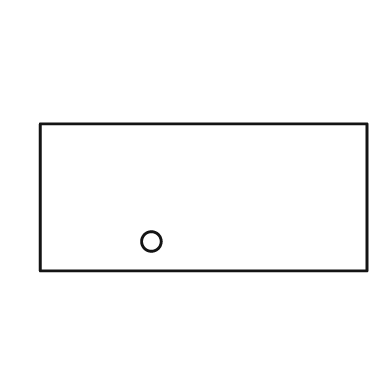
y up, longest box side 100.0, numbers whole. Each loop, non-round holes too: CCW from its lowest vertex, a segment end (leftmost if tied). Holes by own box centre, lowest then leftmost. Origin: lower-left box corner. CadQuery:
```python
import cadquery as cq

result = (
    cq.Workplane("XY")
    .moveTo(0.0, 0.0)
    .lineTo(100.0, 0.0)
    .lineTo(100.0, 45.0)
    .lineTo(0.0, 45.0)
    .close()
    .moveTo(34.0, 9.0)
    .circle(3.0)
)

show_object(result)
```